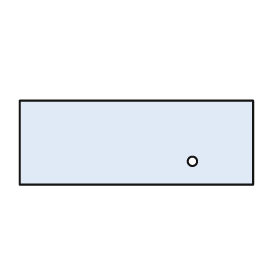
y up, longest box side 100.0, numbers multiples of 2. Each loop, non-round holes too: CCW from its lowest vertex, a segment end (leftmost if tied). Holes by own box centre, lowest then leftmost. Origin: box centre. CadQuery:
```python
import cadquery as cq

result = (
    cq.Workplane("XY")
    .moveTo(-50.0, -18.0)
    .lineTo(50.0, -18.0)
    .lineTo(50.0, 18.0)
    .lineTo(-50.0, 18.0)
    .close()
    .moveTo(24.0, -8.0)
    .circle(2.0)
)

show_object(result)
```